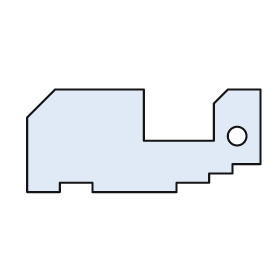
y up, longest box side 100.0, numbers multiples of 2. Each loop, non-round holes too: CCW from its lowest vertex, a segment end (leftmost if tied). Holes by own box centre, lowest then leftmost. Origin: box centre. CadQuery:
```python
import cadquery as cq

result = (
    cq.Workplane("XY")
    .moveTo(-50.0, -22.0)
    .lineTo(-36.0, -22.0)
    .lineTo(-36.0, -18.0)
    .lineTo(-22.0, -18.0)
    .lineTo(-22.0, -22.0)
    .lineTo(14.0, -22.0)
    .lineTo(14.0, -18.0)
    .lineTo(28.0, -18.0)
    .lineTo(28.0, -14.0)
    .lineTo(38.0, -14.0)
    .lineTo(38.0, -10.0)
    .lineTo(50.0, -10.0)
    .lineTo(50.0, 22.0)
    .lineTo(36.0, 22.0)
    .lineTo(30.0, 16.0)
    .lineTo(30.0, 0.0)
    .lineTo(0.0, 0.0)
    .lineTo(0.0, 22.0)
    .lineTo(-38.0, 22.0)
    .lineTo(-50.0, 10.0)
    .close()
    .moveTo(40.0, 2.0)
    .circle(4.0)
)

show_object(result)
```